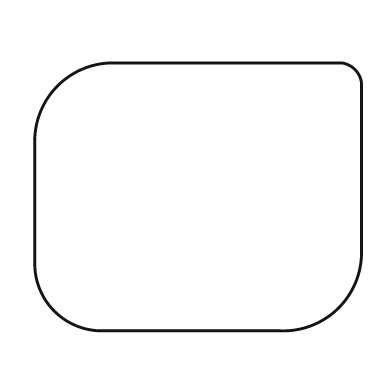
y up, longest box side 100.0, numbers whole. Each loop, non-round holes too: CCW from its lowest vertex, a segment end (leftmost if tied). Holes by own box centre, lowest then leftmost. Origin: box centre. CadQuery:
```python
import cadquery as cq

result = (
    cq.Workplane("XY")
    .moveTo(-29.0, -41.0)
    .lineTo(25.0, -41.0)
    .threePointArc((43.0, -34.0), (50.0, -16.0))
    .lineTo(50.0, 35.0)
    .threePointArc((48.0, 39.0), (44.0, 41.0))
    .lineTo(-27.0, 41.0)
    .threePointArc((-43.0, 34.0), (-50.0, 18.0))
    .lineTo(-50.0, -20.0)
    .threePointArc((-44.0, -35.0), (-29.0, -41.0))
    .close()
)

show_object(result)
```